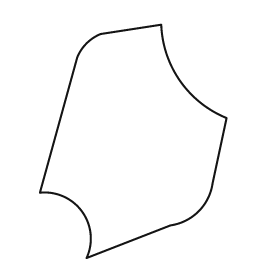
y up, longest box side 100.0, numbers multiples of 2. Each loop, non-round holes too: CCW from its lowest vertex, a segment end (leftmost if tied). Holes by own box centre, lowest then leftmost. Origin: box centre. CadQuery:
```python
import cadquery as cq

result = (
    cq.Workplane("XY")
    .moveTo(-20.0, -50.0)
    .lineTo(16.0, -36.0)
    .threePointArc((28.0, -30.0), (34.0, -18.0))
    .lineTo(40.0, 10.0)
    .threePointArc((20.0, 26.0), (12.0, 50.0))
    .lineTo(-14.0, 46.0)
    .threePointArc((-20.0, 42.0), (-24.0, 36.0))
    .lineTo(-40.0, -22.0)
    .threePointArc((-22.0, -30.0), (-20.0, -50.0))
    .close()
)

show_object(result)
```